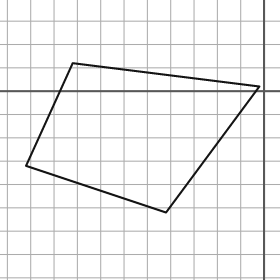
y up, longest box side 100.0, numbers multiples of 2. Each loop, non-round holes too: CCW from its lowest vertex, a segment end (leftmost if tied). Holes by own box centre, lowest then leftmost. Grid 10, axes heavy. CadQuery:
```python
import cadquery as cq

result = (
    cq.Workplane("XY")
    .moveTo(-42.0, -52.0)
    .lineTo(-2.0, 2.0)
    .lineTo(-82.0, 12.0)
    .lineTo(-102.0, -32.0)
    .close()
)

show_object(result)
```